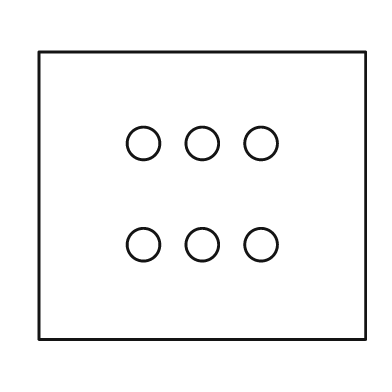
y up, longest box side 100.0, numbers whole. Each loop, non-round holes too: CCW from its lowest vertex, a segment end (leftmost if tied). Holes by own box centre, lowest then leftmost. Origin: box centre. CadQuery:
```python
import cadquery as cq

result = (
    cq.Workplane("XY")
    .moveTo(-50.0, -44.0)
    .lineTo(50.0, -44.0)
    .lineTo(50.0, 44.0)
    .lineTo(-50.0, 44.0)
    .close()
    .moveTo(-18.0, -15.0)
    .circle(5.0)
    .moveTo(0.0, -15.0)
    .circle(5.0)
    .moveTo(18.0, -15.0)
    .circle(5.0)
    .moveTo(-18.0, 16.0)
    .circle(5.0)
    .moveTo(0.0, 16.0)
    .circle(5.0)
    .moveTo(18.0, 16.0)
    .circle(5.0)
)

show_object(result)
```